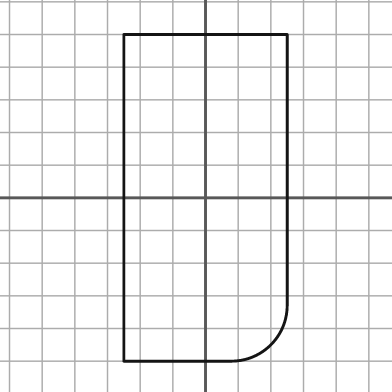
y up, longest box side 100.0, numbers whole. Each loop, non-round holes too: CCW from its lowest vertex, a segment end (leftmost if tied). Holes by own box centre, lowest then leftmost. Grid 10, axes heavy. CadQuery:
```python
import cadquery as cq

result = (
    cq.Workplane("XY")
    .moveTo(-25.0, -50.0)
    .lineTo(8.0, -50.0)
    .threePointArc((20.0, -45.0), (25.0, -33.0))
    .lineTo(25.0, 50.0)
    .lineTo(-25.0, 50.0)
    .close()
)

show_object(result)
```